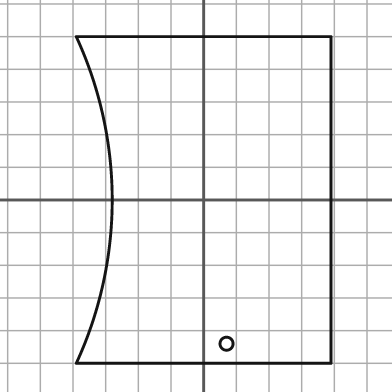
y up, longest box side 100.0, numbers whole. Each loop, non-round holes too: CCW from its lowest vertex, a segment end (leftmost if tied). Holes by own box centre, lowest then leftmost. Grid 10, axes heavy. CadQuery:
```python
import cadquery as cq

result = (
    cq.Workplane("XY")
    .moveTo(-39.0, -50.0)
    .lineTo(39.0, -50.0)
    .lineTo(39.0, 50.0)
    .lineTo(-39.0, 50.0)
    .threePointArc((-28.0, 0.0), (-39.0, -50.0))
    .close()
    .moveTo(7.0, -44.0)
    .circle(2.0)
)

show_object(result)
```